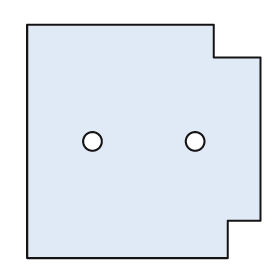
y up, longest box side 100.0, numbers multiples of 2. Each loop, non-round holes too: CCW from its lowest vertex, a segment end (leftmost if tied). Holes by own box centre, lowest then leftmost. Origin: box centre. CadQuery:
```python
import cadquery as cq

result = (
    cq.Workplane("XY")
    .moveTo(-50.0, -50.0)
    .lineTo(36.0, -50.0)
    .lineTo(36.0, -34.0)
    .lineTo(50.0, -34.0)
    .lineTo(50.0, 36.0)
    .lineTo(30.0, 36.0)
    .lineTo(30.0, 50.0)
    .lineTo(-50.0, 50.0)
    .close()
    .moveTo(-22.0, 0.0)
    .circle(4.0)
    .moveTo(22.0, 0.0)
    .circle(4.0)
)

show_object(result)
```